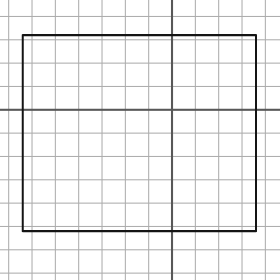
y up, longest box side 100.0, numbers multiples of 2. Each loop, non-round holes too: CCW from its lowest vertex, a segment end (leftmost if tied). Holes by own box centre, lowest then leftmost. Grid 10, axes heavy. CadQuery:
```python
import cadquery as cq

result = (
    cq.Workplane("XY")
    .moveTo(-64.0, -52.0)
    .lineTo(36.0, -52.0)
    .lineTo(36.0, 32.0)
    .lineTo(-64.0, 32.0)
    .close()
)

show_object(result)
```